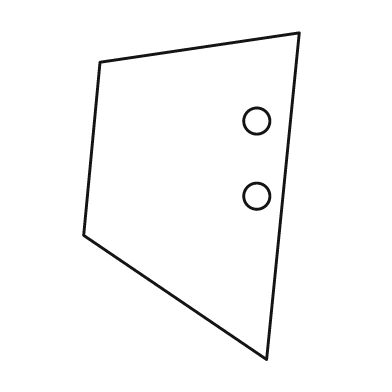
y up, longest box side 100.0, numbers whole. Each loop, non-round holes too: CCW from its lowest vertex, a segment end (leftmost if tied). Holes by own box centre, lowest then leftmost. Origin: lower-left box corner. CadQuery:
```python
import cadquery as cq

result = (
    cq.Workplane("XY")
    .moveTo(56.0, 0.0)
    .lineTo(66.0, 100.0)
    .lineTo(5.0, 91.0)
    .lineTo(0.0, 38.0)
    .close()
    .moveTo(53.0, 50.0)
    .circle(4.0)
    .moveTo(53.0, 73.0)
    .circle(4.0)
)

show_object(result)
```